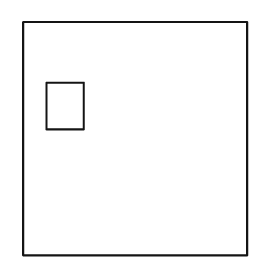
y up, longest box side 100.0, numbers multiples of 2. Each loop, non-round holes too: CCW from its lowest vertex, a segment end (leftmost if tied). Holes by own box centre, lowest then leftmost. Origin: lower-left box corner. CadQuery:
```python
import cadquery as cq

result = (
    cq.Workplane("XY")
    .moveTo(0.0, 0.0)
    .lineTo(96.0, 0.0)
    .lineTo(96.0, 100.0)
    .lineTo(0.0, 100.0)
    .close()
    .moveTo(10.0, 54.0)
    .lineTo(26.0, 54.0)
    .lineTo(26.0, 74.0)
    .lineTo(10.0, 74.0)
    .close()
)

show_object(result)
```